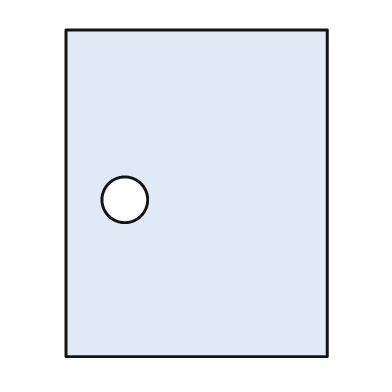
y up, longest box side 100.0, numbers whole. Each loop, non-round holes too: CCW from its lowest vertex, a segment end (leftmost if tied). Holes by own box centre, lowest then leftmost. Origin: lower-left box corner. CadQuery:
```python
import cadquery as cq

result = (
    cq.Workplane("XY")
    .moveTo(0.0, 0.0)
    .lineTo(80.0, 0.0)
    .lineTo(80.0, 100.0)
    .lineTo(0.0, 100.0)
    .close()
    .moveTo(18.0, 48.0)
    .circle(7.0)
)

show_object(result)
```